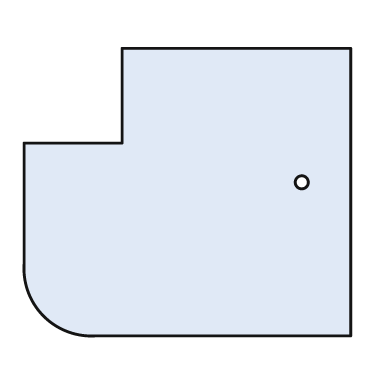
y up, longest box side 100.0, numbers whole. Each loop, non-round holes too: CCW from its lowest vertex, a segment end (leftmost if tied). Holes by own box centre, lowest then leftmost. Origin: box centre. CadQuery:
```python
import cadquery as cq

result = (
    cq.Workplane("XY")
    .moveTo(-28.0, -44.0)
    .lineTo(50.0, -44.0)
    .lineTo(50.0, 44.0)
    .lineTo(-20.0, 44.0)
    .lineTo(-20.0, 15.0)
    .lineTo(-50.0, 15.0)
    .lineTo(-50.0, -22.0)
    .threePointArc((-44.0, -38.0), (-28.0, -44.0))
    .close()
    .moveTo(35.0, 3.0)
    .circle(2.0)
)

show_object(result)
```